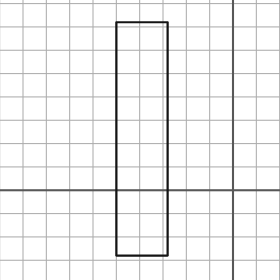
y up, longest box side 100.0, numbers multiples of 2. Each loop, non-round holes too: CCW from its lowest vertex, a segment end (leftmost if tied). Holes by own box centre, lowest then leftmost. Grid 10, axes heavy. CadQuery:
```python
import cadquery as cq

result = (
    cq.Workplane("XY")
    .moveTo(-50.0, -28.0)
    .lineTo(-28.0, -28.0)
    .lineTo(-28.0, 72.0)
    .lineTo(-50.0, 72.0)
    .close()
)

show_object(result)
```